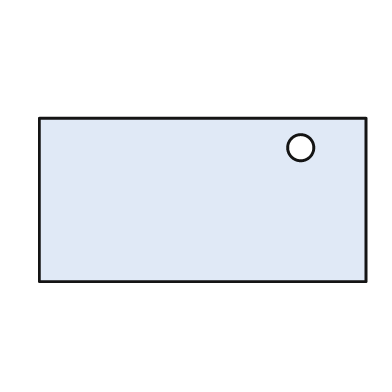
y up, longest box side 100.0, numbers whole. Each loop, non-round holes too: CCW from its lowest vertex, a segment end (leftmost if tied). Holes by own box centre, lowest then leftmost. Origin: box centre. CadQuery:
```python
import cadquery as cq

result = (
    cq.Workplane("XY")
    .moveTo(-50.0, -25.0)
    .lineTo(50.0, -25.0)
    .lineTo(50.0, 25.0)
    .lineTo(-50.0, 25.0)
    .close()
    .moveTo(30.0, 16.0)
    .circle(4.0)
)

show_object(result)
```